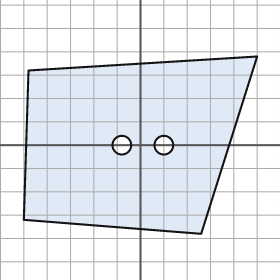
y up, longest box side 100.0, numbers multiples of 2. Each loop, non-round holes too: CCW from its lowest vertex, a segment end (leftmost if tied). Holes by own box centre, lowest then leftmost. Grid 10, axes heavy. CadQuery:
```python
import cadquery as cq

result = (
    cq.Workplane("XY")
    .moveTo(26.0, -38.0)
    .lineTo(50.0, 38.0)
    .lineTo(-48.0, 32.0)
    .lineTo(-50.0, -32.0)
    .close()
    .moveTo(-8.0, 0.0)
    .circle(4.0)
    .moveTo(10.0, 0.0)
    .circle(4.0)
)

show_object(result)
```